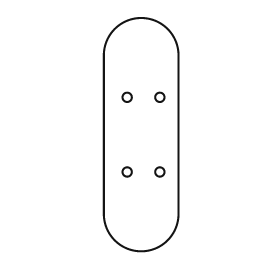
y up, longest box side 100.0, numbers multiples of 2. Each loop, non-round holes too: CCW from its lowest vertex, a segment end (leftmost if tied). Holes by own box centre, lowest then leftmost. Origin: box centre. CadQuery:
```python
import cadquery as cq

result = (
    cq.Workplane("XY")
    .moveTo(-16.0, -34.0)
    .threePointArc((0.0, -50.0), (16.0, -34.0))
    .lineTo(16.0, 34.0)
    .threePointArc((0.0, 50.0), (-16.0, 34.0))
    .close()
    .moveTo(-6.0, -16.0)
    .circle(2.0)
    .moveTo(8.0, -16.0)
    .circle(2.0)
    .moveTo(-6.0, 16.0)
    .circle(2.0)
    .moveTo(8.0, 16.0)
    .circle(2.0)
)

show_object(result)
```